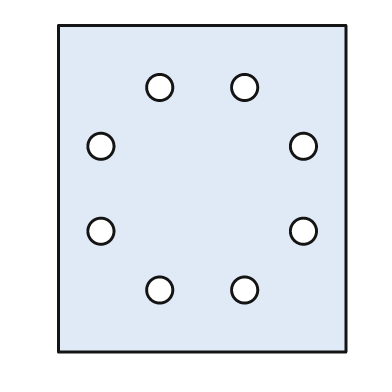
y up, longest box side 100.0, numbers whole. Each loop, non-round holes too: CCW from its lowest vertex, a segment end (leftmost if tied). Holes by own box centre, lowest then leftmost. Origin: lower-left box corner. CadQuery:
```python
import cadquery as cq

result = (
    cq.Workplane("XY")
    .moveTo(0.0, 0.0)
    .lineTo(88.0, 0.0)
    .lineTo(88.0, 100.0)
    .lineTo(0.0, 100.0)
    .close()
    .moveTo(31.0, 19.0)
    .circle(4.0)
    .moveTo(57.0, 19.0)
    .circle(4.0)
    .moveTo(13.0, 37.0)
    .circle(4.0)
    .moveTo(75.0, 37.0)
    .circle(4.0)
    .moveTo(13.0, 63.0)
    .circle(4.0)
    .moveTo(75.0, 63.0)
    .circle(4.0)
    .moveTo(31.0, 81.0)
    .circle(4.0)
    .moveTo(57.0, 81.0)
    .circle(4.0)
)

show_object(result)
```